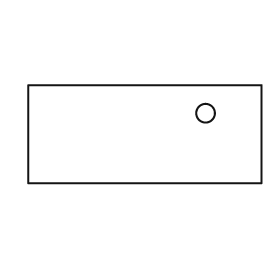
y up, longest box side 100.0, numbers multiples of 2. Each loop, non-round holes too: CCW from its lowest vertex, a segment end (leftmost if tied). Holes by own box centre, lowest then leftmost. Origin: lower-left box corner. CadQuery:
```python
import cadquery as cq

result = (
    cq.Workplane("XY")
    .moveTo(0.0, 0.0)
    .lineTo(100.0, 0.0)
    .lineTo(100.0, 42.0)
    .lineTo(0.0, 42.0)
    .close()
    .moveTo(76.0, 30.0)
    .circle(4.0)
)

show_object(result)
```